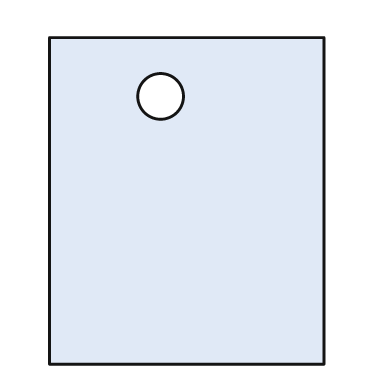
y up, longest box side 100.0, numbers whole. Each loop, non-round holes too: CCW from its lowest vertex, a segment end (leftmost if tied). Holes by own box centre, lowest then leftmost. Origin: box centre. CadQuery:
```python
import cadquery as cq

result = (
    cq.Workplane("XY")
    .moveTo(-42.0, -50.0)
    .lineTo(42.0, -50.0)
    .lineTo(42.0, 50.0)
    .lineTo(-42.0, 50.0)
    .close()
    .moveTo(-8.0, 32.0)
    .circle(7.0)
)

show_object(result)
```